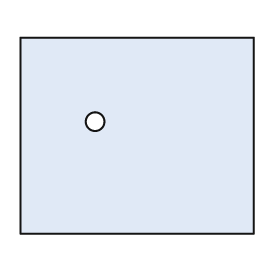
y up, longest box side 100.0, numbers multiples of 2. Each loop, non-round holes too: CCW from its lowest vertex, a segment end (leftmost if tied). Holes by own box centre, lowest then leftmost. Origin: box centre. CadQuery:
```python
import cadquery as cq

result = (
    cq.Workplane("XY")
    .moveTo(-50.0, -42.0)
    .lineTo(50.0, -42.0)
    .lineTo(50.0, 42.0)
    .lineTo(-50.0, 42.0)
    .close()
    .moveTo(-18.0, 6.0)
    .circle(4.0)
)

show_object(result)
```